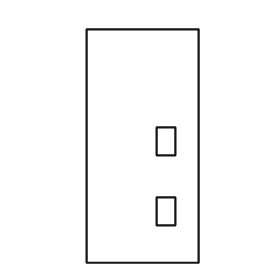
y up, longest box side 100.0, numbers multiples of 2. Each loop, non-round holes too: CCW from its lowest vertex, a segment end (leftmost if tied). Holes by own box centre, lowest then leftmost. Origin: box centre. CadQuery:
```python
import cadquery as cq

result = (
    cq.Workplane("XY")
    .moveTo(-24.0, -50.0)
    .lineTo(24.0, -50.0)
    .lineTo(24.0, 50.0)
    .lineTo(-24.0, 50.0)
    .close()
    .moveTo(6.0, -34.0)
    .lineTo(14.0, -34.0)
    .lineTo(14.0, -22.0)
    .lineTo(6.0, -22.0)
    .close()
    .moveTo(6.0, -4.0)
    .lineTo(14.0, -4.0)
    .lineTo(14.0, 8.0)
    .lineTo(6.0, 8.0)
    .close()
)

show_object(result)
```